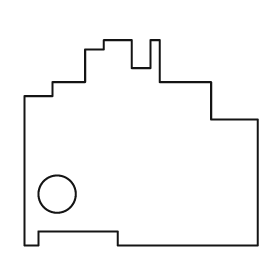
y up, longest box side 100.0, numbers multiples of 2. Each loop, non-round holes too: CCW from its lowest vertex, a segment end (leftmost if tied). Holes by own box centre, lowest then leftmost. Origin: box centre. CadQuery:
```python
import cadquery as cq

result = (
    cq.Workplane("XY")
    .moveTo(-50.0, -44.0)
    .lineTo(-44.0, -44.0)
    .lineTo(-44.0, -38.0)
    .lineTo(-10.0, -38.0)
    .lineTo(-10.0, -44.0)
    .lineTo(50.0, -44.0)
    .lineTo(50.0, 10.0)
    .lineTo(30.0, 10.0)
    .lineTo(30.0, 26.0)
    .lineTo(8.0, 26.0)
    .lineTo(8.0, 44.0)
    .lineTo(4.0, 44.0)
    .lineTo(4.0, 32.0)
    .lineTo(-4.0, 32.0)
    .lineTo(-4.0, 44.0)
    .lineTo(-16.0, 44.0)
    .lineTo(-16.0, 40.0)
    .lineTo(-24.0, 40.0)
    .lineTo(-24.0, 26.0)
    .lineTo(-38.0, 26.0)
    .lineTo(-38.0, 20.0)
    .lineTo(-50.0, 20.0)
    .close()
    .moveTo(-36.0, -22.0)
    .circle(8.0)
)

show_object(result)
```